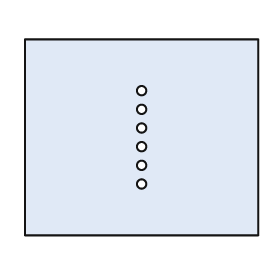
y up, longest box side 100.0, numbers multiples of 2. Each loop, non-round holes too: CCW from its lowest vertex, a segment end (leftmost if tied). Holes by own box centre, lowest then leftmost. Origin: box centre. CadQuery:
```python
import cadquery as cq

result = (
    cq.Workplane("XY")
    .moveTo(-50.0, -42.0)
    .lineTo(50.0, -42.0)
    .lineTo(50.0, 42.0)
    .lineTo(-50.0, 42.0)
    .close()
    .moveTo(0.0, -20.0)
    .circle(2.0)
    .moveTo(0.0, -12.0)
    .circle(2.0)
    .moveTo(0.0, -4.0)
    .circle(2.0)
    .moveTo(0.0, 4.0)
    .circle(2.0)
    .moveTo(0.0, 12.0)
    .circle(2.0)
    .moveTo(0.0, 20.0)
    .circle(2.0)
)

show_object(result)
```